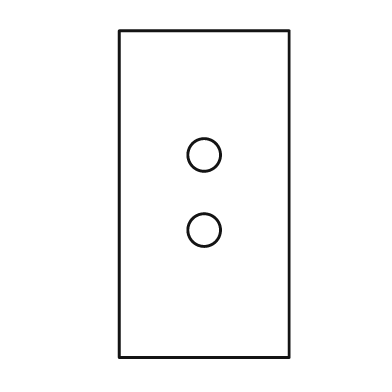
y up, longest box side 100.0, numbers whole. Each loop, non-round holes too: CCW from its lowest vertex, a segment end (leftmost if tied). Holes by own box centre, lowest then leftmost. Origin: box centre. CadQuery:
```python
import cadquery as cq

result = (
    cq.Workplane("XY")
    .moveTo(-26.0, -50.0)
    .lineTo(26.0, -50.0)
    .lineTo(26.0, 50.0)
    .lineTo(-26.0, 50.0)
    .close()
    .moveTo(0.0, -11.0)
    .circle(5.0)
    .moveTo(0.0, 12.0)
    .circle(5.0)
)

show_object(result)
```